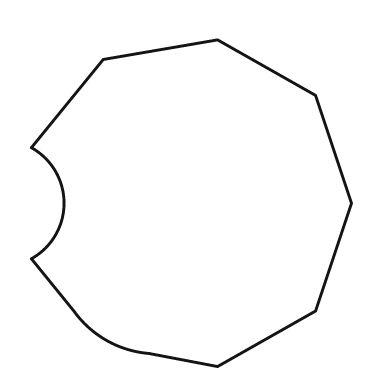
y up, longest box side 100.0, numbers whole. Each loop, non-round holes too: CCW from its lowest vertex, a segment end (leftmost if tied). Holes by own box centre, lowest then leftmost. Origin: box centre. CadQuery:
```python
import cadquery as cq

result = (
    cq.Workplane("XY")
    .moveTo(8.0, -50.0)
    .lineTo(38.0, -33.0)
    .lineTo(49.0, 0.0)
    .lineTo(38.0, 33.0)
    .lineTo(8.0, 50.0)
    .lineTo(-27.0, 44.0)
    .lineTo(-49.0, 17.0)
    .threePointArc((-39.0, 0.0), (-49.0, -17.0))
    .lineTo(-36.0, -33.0)
    .threePointArc((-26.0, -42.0), (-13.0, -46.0))
    .close()
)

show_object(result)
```